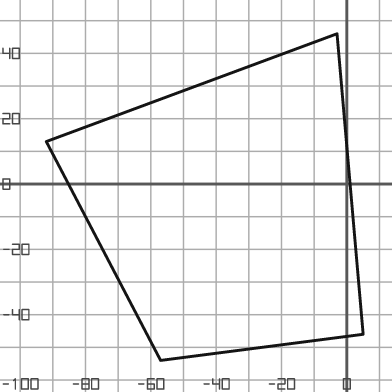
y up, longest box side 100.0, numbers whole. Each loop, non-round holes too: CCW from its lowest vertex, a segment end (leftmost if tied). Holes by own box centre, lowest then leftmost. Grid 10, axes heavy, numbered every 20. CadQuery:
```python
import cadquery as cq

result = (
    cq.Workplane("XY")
    .moveTo(-57.0, -54.0)
    .lineTo(5.0, -46.0)
    .lineTo(-3.0, 46.0)
    .lineTo(-92.0, 13.0)
    .close()
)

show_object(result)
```